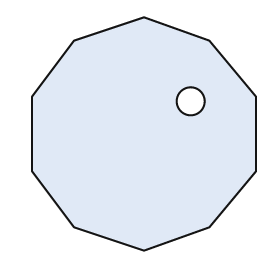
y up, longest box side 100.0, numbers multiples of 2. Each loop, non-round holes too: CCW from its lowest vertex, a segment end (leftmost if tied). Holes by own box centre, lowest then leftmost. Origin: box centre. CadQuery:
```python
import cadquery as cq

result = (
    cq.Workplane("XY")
    .moveTo(0.0, -50.0)
    .lineTo(28.0, -40.0)
    .lineTo(48.0, -16.0)
    .lineTo(48.0, 16.0)
    .lineTo(28.0, 40.0)
    .lineTo(0.0, 50.0)
    .lineTo(-30.0, 40.0)
    .lineTo(-48.0, 16.0)
    .lineTo(-48.0, -16.0)
    .lineTo(-30.0, -40.0)
    .close()
    .moveTo(20.0, 14.0)
    .circle(6.0)
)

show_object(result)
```